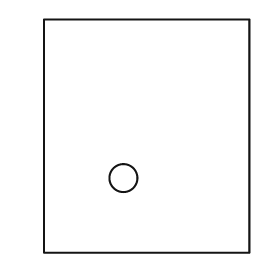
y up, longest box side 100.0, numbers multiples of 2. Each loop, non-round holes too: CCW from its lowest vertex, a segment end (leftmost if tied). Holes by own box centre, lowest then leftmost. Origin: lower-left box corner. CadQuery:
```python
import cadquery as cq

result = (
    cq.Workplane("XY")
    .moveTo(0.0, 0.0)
    .lineTo(88.0, 0.0)
    .lineTo(88.0, 100.0)
    .lineTo(0.0, 100.0)
    .close()
    .moveTo(34.0, 32.0)
    .circle(6.0)
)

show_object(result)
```